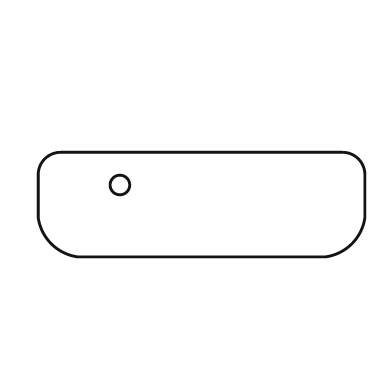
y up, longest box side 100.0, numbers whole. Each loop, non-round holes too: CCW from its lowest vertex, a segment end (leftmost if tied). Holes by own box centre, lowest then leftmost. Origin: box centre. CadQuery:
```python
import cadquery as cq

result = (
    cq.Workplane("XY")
    .moveTo(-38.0, -16.0)
    .lineTo(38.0, -16.0)
    .threePointArc((46.0, -12.0), (50.0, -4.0))
    .lineTo(50.0, 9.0)
    .threePointArc((48.0, 14.0), (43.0, 16.0))
    .lineTo(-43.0, 16.0)
    .threePointArc((-48.0, 14.0), (-50.0, 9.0))
    .lineTo(-50.0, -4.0)
    .threePointArc((-46.0, -12.0), (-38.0, -16.0))
    .close()
    .moveTo(-25.0, 6.0)
    .circle(3.0)
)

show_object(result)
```